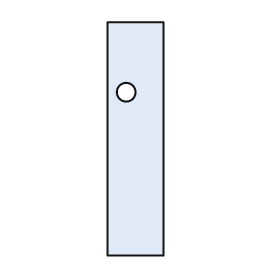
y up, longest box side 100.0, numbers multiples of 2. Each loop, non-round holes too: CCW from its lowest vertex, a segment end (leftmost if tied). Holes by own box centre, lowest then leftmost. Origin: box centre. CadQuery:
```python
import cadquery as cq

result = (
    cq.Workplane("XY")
    .moveTo(-12.0, -50.0)
    .lineTo(12.0, -50.0)
    .lineTo(12.0, 50.0)
    .lineTo(-12.0, 50.0)
    .close()
    .moveTo(-4.0, 20.0)
    .circle(4.0)
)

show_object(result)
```